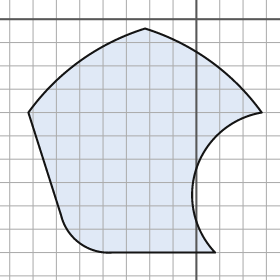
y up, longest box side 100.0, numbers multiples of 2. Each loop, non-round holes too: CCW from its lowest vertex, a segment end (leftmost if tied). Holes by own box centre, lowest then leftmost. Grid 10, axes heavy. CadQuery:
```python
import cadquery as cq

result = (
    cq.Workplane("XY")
    .moveTo(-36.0, -100.0)
    .lineTo(8.0, -100.0)
    .threePointArc((0.0, -64.0), (28.0, -40.0))
    .threePointArc((6.0, -18.0), (-22.0, -4.0))
    .threePointArc((-50.0, -18.0), (-72.0, -40.0))
    .lineTo(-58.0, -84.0)
    .threePointArc((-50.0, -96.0), (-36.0, -100.0))
    .close()
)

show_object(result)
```